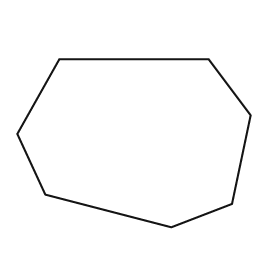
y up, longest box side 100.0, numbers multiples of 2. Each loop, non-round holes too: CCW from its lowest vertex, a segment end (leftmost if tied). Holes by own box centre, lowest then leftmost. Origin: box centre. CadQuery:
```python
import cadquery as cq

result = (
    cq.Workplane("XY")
    .moveTo(16.0, -36.0)
    .lineTo(42.0, -26.0)
    .lineTo(50.0, 12.0)
    .lineTo(32.0, 36.0)
    .lineTo(-32.0, 36.0)
    .lineTo(-50.0, 4.0)
    .lineTo(-38.0, -22.0)
    .close()
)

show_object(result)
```